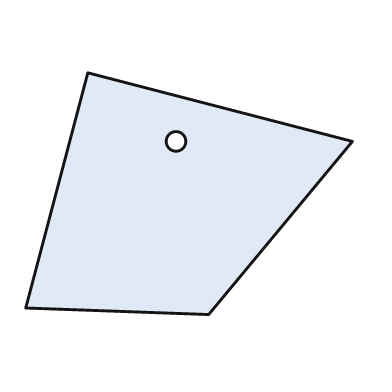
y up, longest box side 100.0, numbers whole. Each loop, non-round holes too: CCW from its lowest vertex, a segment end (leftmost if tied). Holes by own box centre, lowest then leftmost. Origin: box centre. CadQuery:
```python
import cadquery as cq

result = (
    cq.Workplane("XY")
    .moveTo(6.0, -37.0)
    .lineTo(50.0, 16.0)
    .lineTo(-31.0, 37.0)
    .lineTo(-50.0, -35.0)
    .close()
    .moveTo(-4.0, 16.0)
    .circle(3.0)
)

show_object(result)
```